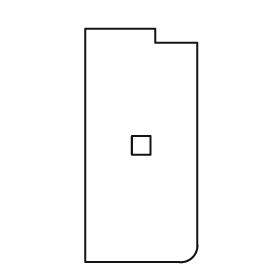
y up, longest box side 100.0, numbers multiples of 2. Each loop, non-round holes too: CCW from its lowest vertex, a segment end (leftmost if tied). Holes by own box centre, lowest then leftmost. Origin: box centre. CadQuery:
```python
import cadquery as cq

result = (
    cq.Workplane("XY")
    .moveTo(-24.0, -50.0)
    .lineTo(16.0, -50.0)
    .threePointArc((22.0, -48.0), (24.0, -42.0))
    .lineTo(24.0, 44.0)
    .lineTo(6.0, 44.0)
    .lineTo(6.0, 50.0)
    .lineTo(-24.0, 50.0)
    .close()
    .moveTo(-4.0, -4.0)
    .lineTo(4.0, -4.0)
    .lineTo(4.0, 4.0)
    .lineTo(-4.0, 4.0)
    .close()
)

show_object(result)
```